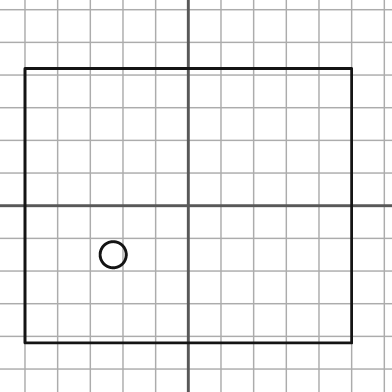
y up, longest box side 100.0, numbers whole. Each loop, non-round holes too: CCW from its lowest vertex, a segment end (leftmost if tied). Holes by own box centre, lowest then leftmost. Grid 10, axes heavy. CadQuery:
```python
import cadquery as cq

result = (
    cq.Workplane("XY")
    .moveTo(-50.0, -42.0)
    .lineTo(50.0, -42.0)
    .lineTo(50.0, 42.0)
    .lineTo(-50.0, 42.0)
    .close()
    .moveTo(-23.0, -15.0)
    .circle(4.0)
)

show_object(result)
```